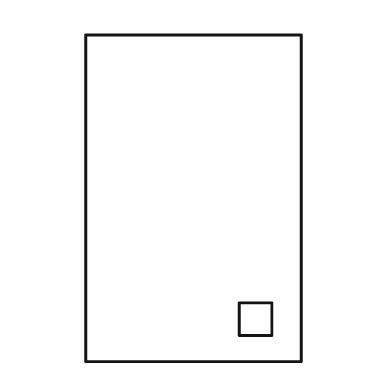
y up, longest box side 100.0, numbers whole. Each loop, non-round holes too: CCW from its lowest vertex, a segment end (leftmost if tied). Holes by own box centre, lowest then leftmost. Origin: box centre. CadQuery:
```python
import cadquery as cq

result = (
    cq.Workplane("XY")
    .moveTo(-33.0, -50.0)
    .lineTo(33.0, -50.0)
    .lineTo(33.0, 50.0)
    .lineTo(-33.0, 50.0)
    .close()
    .moveTo(14.0, -42.0)
    .lineTo(24.0, -42.0)
    .lineTo(24.0, -32.0)
    .lineTo(14.0, -32.0)
    .close()
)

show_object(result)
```